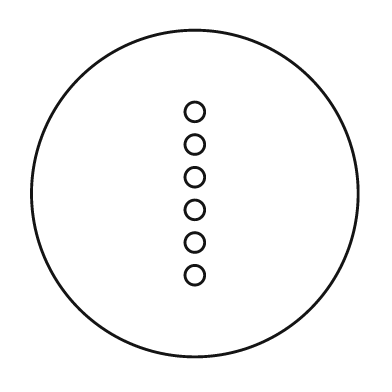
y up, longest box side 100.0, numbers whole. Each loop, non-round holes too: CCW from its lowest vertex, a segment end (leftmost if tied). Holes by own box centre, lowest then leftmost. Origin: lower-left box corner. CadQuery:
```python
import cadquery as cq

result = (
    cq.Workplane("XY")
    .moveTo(50.0, 50.0)
    .circle(50.0)
    .moveTo(50.0, 25.0)
    .circle(3.0)
    .moveTo(50.0, 35.0)
    .circle(3.0)
    .moveTo(50.0, 45.0)
    .circle(3.0)
    .moveTo(50.0, 55.0)
    .circle(3.0)
    .moveTo(50.0, 65.0)
    .circle(3.0)
    .moveTo(50.0, 75.0)
    .circle(3.0)
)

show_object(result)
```